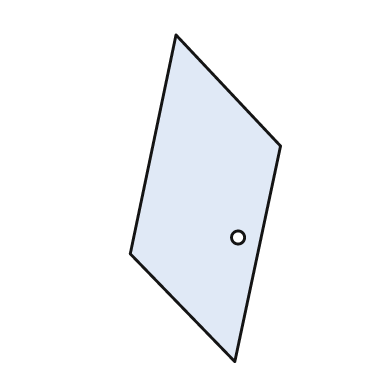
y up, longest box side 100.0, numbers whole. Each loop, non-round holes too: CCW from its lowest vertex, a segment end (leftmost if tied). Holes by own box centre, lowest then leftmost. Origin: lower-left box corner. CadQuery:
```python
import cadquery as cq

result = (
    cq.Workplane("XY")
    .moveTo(32.0, 0.0)
    .lineTo(46.0, 66.0)
    .lineTo(14.0, 100.0)
    .lineTo(0.0, 33.0)
    .close()
    .moveTo(33.0, 38.0)
    .circle(2.0)
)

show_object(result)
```